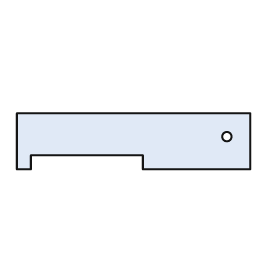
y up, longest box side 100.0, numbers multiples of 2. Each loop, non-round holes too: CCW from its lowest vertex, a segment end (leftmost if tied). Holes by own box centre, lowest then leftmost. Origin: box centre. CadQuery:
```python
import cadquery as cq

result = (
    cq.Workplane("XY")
    .moveTo(-50.0, -12.0)
    .lineTo(-44.0, -12.0)
    .lineTo(-44.0, -6.0)
    .lineTo(4.0, -6.0)
    .lineTo(4.0, -12.0)
    .lineTo(50.0, -12.0)
    .lineTo(50.0, 12.0)
    .lineTo(-50.0, 12.0)
    .close()
    .moveTo(40.0, 2.0)
    .circle(2.0)
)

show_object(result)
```